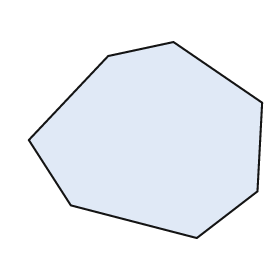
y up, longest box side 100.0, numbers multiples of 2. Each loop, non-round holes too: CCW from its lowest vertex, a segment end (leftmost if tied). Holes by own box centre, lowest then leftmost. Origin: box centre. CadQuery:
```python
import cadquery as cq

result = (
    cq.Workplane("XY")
    .moveTo(22.0, -42.0)
    .lineTo(48.0, -22.0)
    .lineTo(50.0, 16.0)
    .lineTo(12.0, 42.0)
    .lineTo(-16.0, 36.0)
    .lineTo(-50.0, 0.0)
    .lineTo(-32.0, -28.0)
    .close()
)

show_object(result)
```